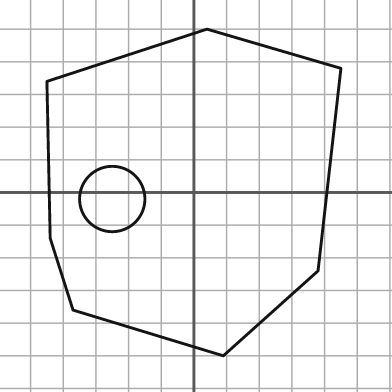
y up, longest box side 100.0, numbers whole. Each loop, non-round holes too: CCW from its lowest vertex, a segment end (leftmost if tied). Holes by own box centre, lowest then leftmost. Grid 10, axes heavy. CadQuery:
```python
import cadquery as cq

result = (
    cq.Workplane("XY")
    .moveTo(9.0, -50.0)
    .lineTo(38.0, -24.0)
    .lineTo(45.0, 38.0)
    .lineTo(4.0, 50.0)
    .lineTo(-45.0, 34.0)
    .lineTo(-44.0, -14.0)
    .lineTo(-37.0, -36.0)
    .close()
    .moveTo(-25.0, -2.0)
    .circle(10.0)
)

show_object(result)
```